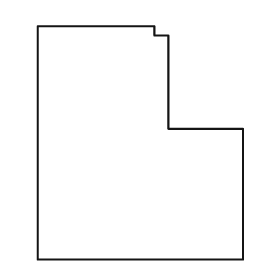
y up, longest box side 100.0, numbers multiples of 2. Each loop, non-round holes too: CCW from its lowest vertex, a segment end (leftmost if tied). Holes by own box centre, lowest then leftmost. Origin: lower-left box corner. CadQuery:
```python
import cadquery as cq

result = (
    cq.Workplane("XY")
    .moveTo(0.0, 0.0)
    .lineTo(88.0, 0.0)
    .lineTo(88.0, 56.0)
    .lineTo(56.0, 56.0)
    .lineTo(56.0, 96.0)
    .lineTo(50.0, 96.0)
    .lineTo(50.0, 100.0)
    .lineTo(0.0, 100.0)
    .close()
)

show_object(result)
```